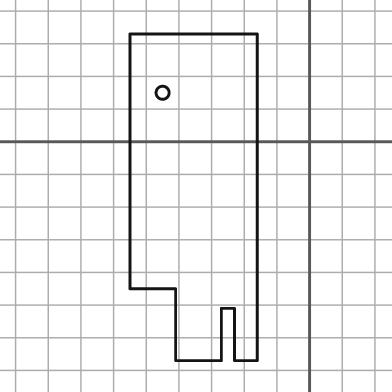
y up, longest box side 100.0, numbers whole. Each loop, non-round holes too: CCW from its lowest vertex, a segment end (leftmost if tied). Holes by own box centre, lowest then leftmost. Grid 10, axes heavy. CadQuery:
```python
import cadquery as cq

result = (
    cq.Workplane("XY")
    .moveTo(-41.0, -67.0)
    .lineTo(-27.0, -67.0)
    .lineTo(-27.0, -51.0)
    .lineTo(-23.0, -51.0)
    .lineTo(-23.0, -67.0)
    .lineTo(-16.0, -67.0)
    .lineTo(-16.0, 33.0)
    .lineTo(-55.0, 33.0)
    .lineTo(-55.0, -45.0)
    .lineTo(-41.0, -45.0)
    .close()
    .moveTo(-45.0, 15.0)
    .circle(2.0)
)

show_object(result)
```